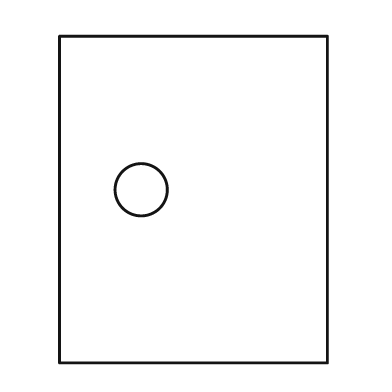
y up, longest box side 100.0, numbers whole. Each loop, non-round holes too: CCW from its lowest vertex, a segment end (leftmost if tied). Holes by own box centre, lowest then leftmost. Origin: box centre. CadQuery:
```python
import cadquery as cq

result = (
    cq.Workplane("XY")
    .moveTo(-41.0, -50.0)
    .lineTo(41.0, -50.0)
    .lineTo(41.0, 50.0)
    .lineTo(-41.0, 50.0)
    .close()
    .moveTo(-16.0, 3.0)
    .circle(8.0)
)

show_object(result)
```